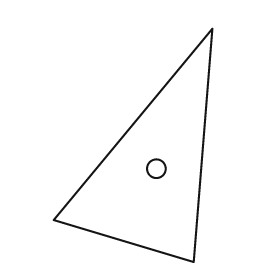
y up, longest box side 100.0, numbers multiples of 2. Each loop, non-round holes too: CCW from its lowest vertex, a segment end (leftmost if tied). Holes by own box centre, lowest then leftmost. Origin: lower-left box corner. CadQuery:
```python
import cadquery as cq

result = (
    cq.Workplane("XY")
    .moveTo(60.0, 0.0)
    .lineTo(68.0, 100.0)
    .lineTo(0.0, 18.0)
    .close()
    .moveTo(44.0, 40.0)
    .circle(4.0)
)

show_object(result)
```